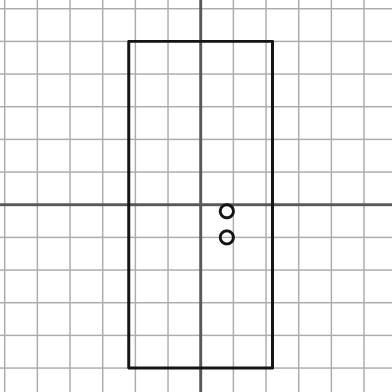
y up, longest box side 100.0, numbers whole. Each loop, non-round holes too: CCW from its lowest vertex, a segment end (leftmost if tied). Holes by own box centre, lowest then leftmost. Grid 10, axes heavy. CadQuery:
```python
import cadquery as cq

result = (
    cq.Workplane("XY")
    .moveTo(-22.0, -50.0)
    .lineTo(22.0, -50.0)
    .lineTo(22.0, 50.0)
    .lineTo(-22.0, 50.0)
    .close()
    .moveTo(8.0, -10.0)
    .circle(2.0)
    .moveTo(8.0, -2.0)
    .circle(2.0)
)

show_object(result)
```